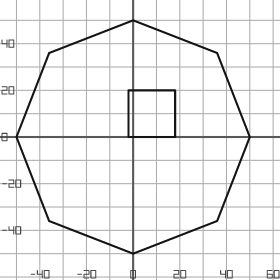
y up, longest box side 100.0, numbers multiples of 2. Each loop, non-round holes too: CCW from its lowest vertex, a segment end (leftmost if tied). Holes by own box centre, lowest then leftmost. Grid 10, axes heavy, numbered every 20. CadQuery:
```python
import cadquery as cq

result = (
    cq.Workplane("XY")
    .moveTo(0.0, -50.0)
    .lineTo(36.0, -36.0)
    .lineTo(50.0, 0.0)
    .lineTo(36.0, 36.0)
    .lineTo(0.0, 50.0)
    .lineTo(-36.0, 36.0)
    .lineTo(-50.0, 0.0)
    .lineTo(-36.0, -36.0)
    .close()
    .moveTo(-2.0, 0.0)
    .lineTo(18.0, 0.0)
    .lineTo(18.0, 20.0)
    .lineTo(-2.0, 20.0)
    .close()
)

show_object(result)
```